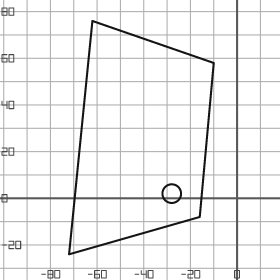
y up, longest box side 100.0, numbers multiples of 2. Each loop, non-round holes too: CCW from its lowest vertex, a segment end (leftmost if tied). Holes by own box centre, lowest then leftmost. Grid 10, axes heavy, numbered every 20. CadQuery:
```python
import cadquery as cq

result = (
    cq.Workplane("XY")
    .moveTo(-72.0, -24.0)
    .lineTo(-16.0, -8.0)
    .lineTo(-10.0, 58.0)
    .lineTo(-62.0, 76.0)
    .close()
    .moveTo(-28.0, 2.0)
    .circle(4.0)
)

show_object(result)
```